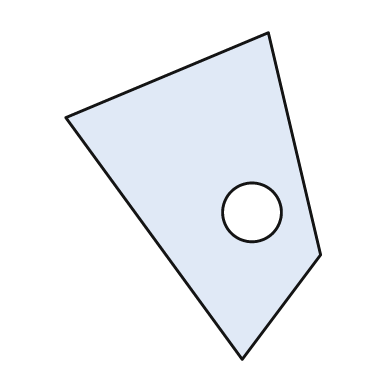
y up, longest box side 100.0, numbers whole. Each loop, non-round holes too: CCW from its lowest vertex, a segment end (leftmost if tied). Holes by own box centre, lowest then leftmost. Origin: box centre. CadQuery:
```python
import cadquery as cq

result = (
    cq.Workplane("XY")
    .moveTo(15.0, -50.0)
    .lineTo(39.0, -18.0)
    .lineTo(23.0, 50.0)
    .lineTo(-39.0, 24.0)
    .close()
    .moveTo(18.0, -5.0)
    .circle(9.0)
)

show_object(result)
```